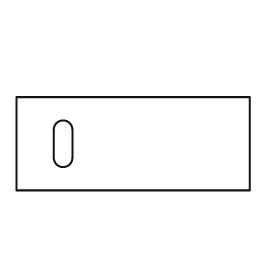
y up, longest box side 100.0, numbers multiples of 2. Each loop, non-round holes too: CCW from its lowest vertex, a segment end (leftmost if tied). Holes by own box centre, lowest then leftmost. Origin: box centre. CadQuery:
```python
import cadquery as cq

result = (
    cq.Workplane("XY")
    .moveTo(-50.0, -20.0)
    .lineTo(50.0, -20.0)
    .lineTo(50.0, 20.0)
    .lineTo(-50.0, 20.0)
    .close()
    .moveTo(-34.0, -6.0)
    .threePointArc((-30.0, -10.0), (-26.0, -6.0))
    .lineTo(-26.0, 6.0)
    .threePointArc((-30.0, 10.0), (-34.0, 6.0))
    .close()
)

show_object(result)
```